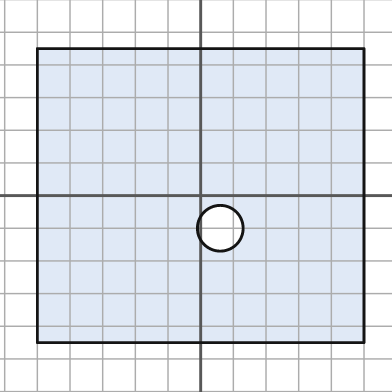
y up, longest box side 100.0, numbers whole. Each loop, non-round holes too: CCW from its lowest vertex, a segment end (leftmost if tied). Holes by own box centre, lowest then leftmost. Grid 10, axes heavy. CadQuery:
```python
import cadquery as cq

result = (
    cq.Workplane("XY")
    .moveTo(-50.0, -45.0)
    .lineTo(50.0, -45.0)
    .lineTo(50.0, 45.0)
    .lineTo(-50.0, 45.0)
    .close()
    .moveTo(6.0, -10.0)
    .circle(7.0)
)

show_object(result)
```